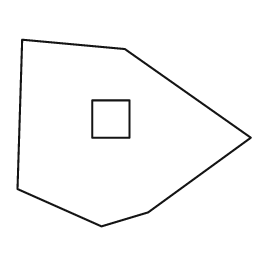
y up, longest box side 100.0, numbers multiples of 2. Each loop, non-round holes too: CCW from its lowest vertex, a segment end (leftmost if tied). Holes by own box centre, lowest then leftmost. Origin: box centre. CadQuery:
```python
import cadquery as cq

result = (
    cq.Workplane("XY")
    .moveTo(-14.0, -40.0)
    .lineTo(6.0, -34.0)
    .lineTo(50.0, -2.0)
    .lineTo(-4.0, 36.0)
    .lineTo(-48.0, 40.0)
    .lineTo(-50.0, -24.0)
    .close()
    .moveTo(-18.0, -2.0)
    .lineTo(-2.0, -2.0)
    .lineTo(-2.0, 14.0)
    .lineTo(-18.0, 14.0)
    .close()
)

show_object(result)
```